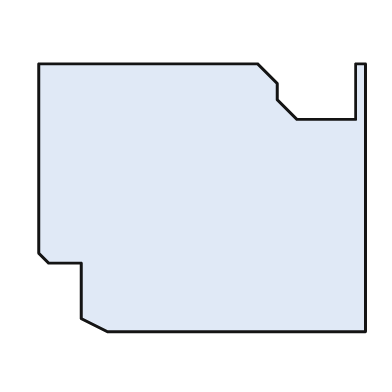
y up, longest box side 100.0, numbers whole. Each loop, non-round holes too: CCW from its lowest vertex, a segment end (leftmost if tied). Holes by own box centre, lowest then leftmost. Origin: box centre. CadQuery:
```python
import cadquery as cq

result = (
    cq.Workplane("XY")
    .moveTo(-29.0, -41.0)
    .lineTo(50.0, -41.0)
    .lineTo(50.0, 41.0)
    .lineTo(47.0, 41.0)
    .lineTo(47.0, 24.0)
    .lineTo(29.0, 24.0)
    .lineTo(23.0, 30.0)
    .lineTo(23.0, 35.0)
    .lineTo(17.0, 41.0)
    .lineTo(-50.0, 41.0)
    .lineTo(-50.0, -17.0)
    .lineTo(-47.0, -20.0)
    .lineTo(-37.0, -20.0)
    .lineTo(-37.0, -37.0)
    .close()
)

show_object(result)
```